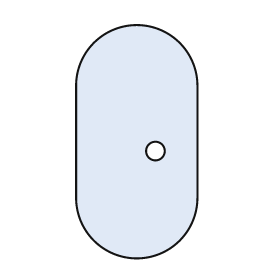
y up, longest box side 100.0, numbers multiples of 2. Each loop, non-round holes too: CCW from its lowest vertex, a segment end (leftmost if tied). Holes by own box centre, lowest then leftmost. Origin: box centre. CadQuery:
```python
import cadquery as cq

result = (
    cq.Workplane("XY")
    .moveTo(-26.0, -24.0)
    .threePointArc((0.0, -50.0), (26.0, -24.0))
    .lineTo(26.0, 24.0)
    .threePointArc((0.0, 50.0), (-26.0, 24.0))
    .close()
    .moveTo(8.0, -4.0)
    .circle(4.0)
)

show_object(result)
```